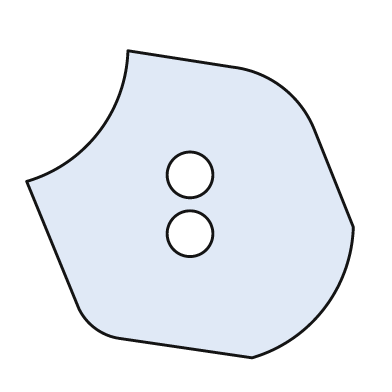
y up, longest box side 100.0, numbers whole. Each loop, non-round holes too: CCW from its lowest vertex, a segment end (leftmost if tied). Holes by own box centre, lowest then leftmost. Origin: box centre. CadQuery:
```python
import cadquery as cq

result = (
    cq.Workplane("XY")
    .moveTo(19.0, -47.0)
    .threePointArc((41.0, -32.0), (50.0, -7.0))
    .lineTo(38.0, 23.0)
    .threePointArc((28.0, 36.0), (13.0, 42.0))
    .lineTo(-19.0, 47.0)
    .threePointArc((-28.0, 22.0), (-50.0, 7.0))
    .lineTo(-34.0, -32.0)
    .threePointArc((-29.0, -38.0), (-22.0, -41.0))
    .close()
    .moveTo(0.0, -9.0)
    .circle(7.0)
    .moveTo(0.0, 9.0)
    .circle(7.0)
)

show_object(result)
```